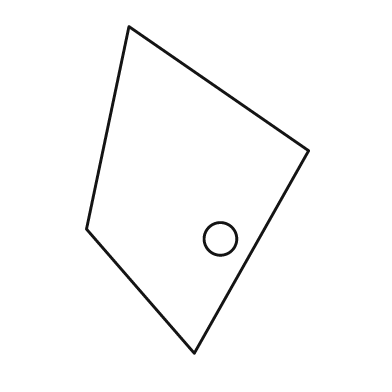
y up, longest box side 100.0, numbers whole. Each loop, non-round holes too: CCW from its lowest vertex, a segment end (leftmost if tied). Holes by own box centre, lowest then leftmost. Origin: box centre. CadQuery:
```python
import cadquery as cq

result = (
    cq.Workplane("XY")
    .moveTo(-1.0, -50.0)
    .lineTo(34.0, 12.0)
    .lineTo(-21.0, 50.0)
    .lineTo(-34.0, -12.0)
    .close()
    .moveTo(7.0, -15.0)
    .circle(5.0)
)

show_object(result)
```